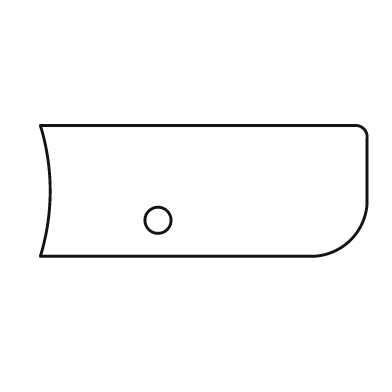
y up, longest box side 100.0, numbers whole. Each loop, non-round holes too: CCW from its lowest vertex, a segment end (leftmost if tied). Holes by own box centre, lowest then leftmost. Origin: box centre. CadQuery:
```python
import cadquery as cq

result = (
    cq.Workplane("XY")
    .moveTo(-50.0, -20.0)
    .lineTo(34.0, -20.0)
    .threePointArc((45.0, -15.0), (50.0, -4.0))
    .lineTo(50.0, 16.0)
    .threePointArc((49.0, 19.0), (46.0, 20.0))
    .lineTo(-50.0, 20.0)
    .threePointArc((-47.0, 0.0), (-50.0, -20.0))
    .close()
    .moveTo(-14.0, -9.0)
    .circle(4.0)
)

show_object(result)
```